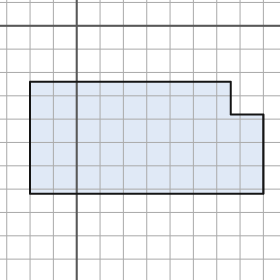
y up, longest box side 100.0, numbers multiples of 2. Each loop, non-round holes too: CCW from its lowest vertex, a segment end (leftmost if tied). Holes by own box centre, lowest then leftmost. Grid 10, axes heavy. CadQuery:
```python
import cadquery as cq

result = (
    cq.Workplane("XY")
    .moveTo(-20.0, -72.0)
    .lineTo(80.0, -72.0)
    .lineTo(80.0, -38.0)
    .lineTo(66.0, -38.0)
    .lineTo(66.0, -24.0)
    .lineTo(-20.0, -24.0)
    .close()
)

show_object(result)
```